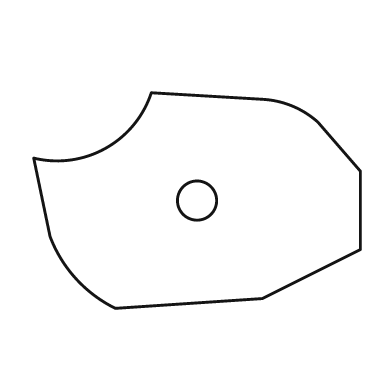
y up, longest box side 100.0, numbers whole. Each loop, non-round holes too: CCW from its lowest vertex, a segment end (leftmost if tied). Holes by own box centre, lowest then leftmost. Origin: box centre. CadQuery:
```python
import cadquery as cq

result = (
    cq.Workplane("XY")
    .moveTo(-25.0, -33.0)
    .lineTo(20.0, -30.0)
    .lineTo(50.0, -15.0)
    .lineTo(50.0, 9.0)
    .lineTo(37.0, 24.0)
    .threePointArc((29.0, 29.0), (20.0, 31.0))
    .lineTo(-14.0, 33.0)
    .threePointArc((-28.0, 16.0), (-50.0, 13.0))
    .lineTo(-45.0, -11.0)
    .threePointArc((-37.0, -24.0), (-25.0, -33.0))
    .close()
    .moveTo(0.0, 0.0)
    .circle(6.0)
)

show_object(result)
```